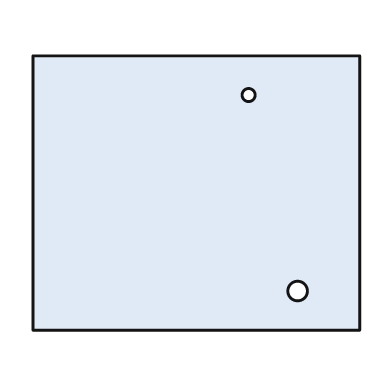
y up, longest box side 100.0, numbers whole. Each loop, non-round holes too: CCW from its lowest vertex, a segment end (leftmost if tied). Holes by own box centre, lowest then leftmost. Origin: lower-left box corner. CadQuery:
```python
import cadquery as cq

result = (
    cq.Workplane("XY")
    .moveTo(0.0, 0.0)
    .lineTo(100.0, 0.0)
    .lineTo(100.0, 84.0)
    .lineTo(0.0, 84.0)
    .close()
    .moveTo(81.0, 12.0)
    .circle(3.0)
    .moveTo(66.0, 72.0)
    .circle(2.0)
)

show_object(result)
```